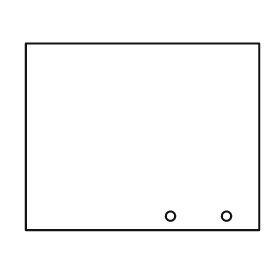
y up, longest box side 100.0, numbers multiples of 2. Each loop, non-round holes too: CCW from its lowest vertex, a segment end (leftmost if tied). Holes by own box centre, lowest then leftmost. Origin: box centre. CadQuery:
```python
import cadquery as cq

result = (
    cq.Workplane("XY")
    .moveTo(-50.0, -40.0)
    .lineTo(50.0, -40.0)
    .lineTo(50.0, 40.0)
    .lineTo(-50.0, 40.0)
    .close()
    .moveTo(12.0, -34.0)
    .circle(2.0)
    .moveTo(36.0, -34.0)
    .circle(2.0)
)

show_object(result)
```